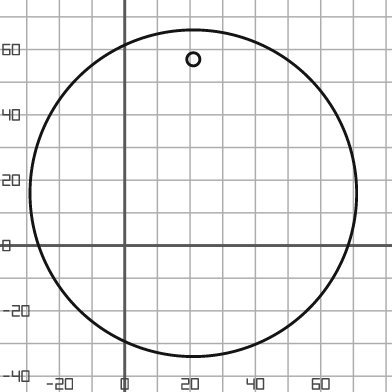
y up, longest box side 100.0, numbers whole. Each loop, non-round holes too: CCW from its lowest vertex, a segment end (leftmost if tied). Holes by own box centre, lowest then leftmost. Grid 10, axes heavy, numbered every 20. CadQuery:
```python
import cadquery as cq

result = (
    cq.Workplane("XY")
    .moveTo(21.0, 16.0)
    .circle(50.0)
    .moveTo(21.0, 57.0)
    .circle(2.0)
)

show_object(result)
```